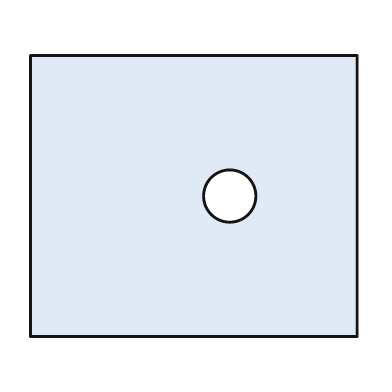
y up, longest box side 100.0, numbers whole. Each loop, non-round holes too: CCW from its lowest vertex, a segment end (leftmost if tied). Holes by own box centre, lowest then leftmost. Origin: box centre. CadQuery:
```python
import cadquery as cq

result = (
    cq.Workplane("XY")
    .moveTo(-50.0, -43.0)
    .lineTo(50.0, -43.0)
    .lineTo(50.0, 43.0)
    .lineTo(-50.0, 43.0)
    .close()
    .moveTo(11.0, 0.0)
    .circle(8.0)
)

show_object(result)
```